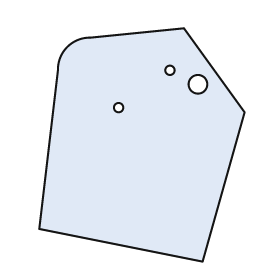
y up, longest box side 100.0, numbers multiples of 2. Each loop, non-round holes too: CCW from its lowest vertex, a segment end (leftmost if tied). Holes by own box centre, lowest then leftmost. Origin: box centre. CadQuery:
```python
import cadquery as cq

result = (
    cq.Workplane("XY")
    .moveTo(26.0, -50.0)
    .lineTo(44.0, 14.0)
    .lineTo(18.0, 50.0)
    .lineTo(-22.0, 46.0)
    .threePointArc((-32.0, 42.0), (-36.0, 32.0))
    .lineTo(-44.0, -36.0)
    .close()
    .moveTo(-10.0, 16.0)
    .circle(2.0)
    .moveTo(24.0, 26.0)
    .circle(4.0)
    .moveTo(12.0, 32.0)
    .circle(2.0)
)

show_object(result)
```